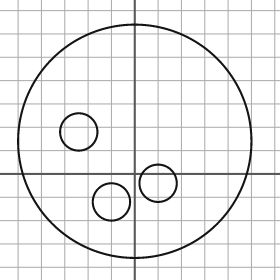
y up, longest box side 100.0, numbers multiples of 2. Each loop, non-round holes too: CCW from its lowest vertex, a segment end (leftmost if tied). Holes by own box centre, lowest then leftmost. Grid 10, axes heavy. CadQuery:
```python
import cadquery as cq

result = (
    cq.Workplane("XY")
    .moveTo(0.0, 14.0)
    .circle(50.0)
    .moveTo(-10.0, -12.0)
    .circle(8.0)
    .moveTo(10.0, -4.0)
    .circle(8.0)
    .moveTo(-24.0, 18.0)
    .circle(8.0)
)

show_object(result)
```